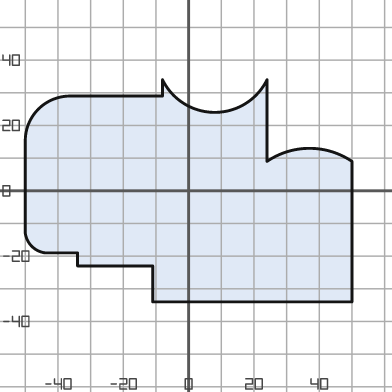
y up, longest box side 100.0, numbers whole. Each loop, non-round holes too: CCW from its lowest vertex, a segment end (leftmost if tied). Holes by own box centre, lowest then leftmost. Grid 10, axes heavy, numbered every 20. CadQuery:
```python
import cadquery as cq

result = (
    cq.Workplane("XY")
    .moveTo(-11.0, -34.0)
    .lineTo(50.0, -34.0)
    .lineTo(50.0, 9.0)
    .threePointArc((37.0, 13.0), (24.0, 9.0))
    .lineTo(24.0, 34.0)
    .threePointArc((8.0, 24.0), (-8.0, 34.0))
    .lineTo(-8.0, 29.0)
    .lineTo(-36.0, 29.0)
    .threePointArc((-46.0, 25.0), (-50.0, 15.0))
    .lineTo(-50.0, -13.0)
    .threePointArc((-48.0, -17.0), (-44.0, -19.0))
    .lineTo(-34.0, -19.0)
    .lineTo(-34.0, -23.0)
    .lineTo(-11.0, -23.0)
    .close()
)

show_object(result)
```